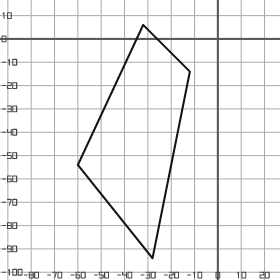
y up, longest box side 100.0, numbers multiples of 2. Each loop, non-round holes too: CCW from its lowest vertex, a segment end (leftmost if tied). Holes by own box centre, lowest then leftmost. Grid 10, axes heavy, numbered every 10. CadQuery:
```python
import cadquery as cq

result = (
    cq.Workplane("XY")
    .moveTo(-28.0, -94.0)
    .lineTo(-12.0, -14.0)
    .lineTo(-32.0, 6.0)
    .lineTo(-60.0, -54.0)
    .close()
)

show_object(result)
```